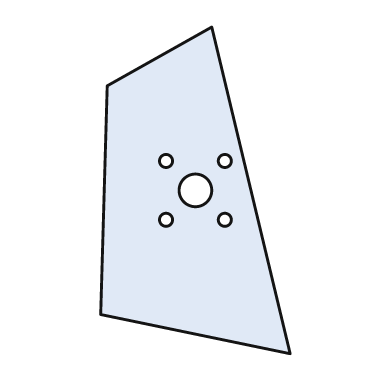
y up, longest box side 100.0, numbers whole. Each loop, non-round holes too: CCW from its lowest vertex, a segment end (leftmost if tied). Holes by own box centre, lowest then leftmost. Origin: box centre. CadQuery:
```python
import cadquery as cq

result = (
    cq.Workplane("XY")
    .moveTo(29.0, -50.0)
    .lineTo(5.0, 50.0)
    .lineTo(-27.0, 32.0)
    .lineTo(-29.0, -38.0)
    .close()
    .moveTo(-9.0, -9.0)
    .circle(2.0)
    .moveTo(9.0, -9.0)
    .circle(2.0)
    .moveTo(0.0, 0.0)
    .circle(5.0)
    .moveTo(-9.0, 9.0)
    .circle(2.0)
    .moveTo(9.0, 9.0)
    .circle(2.0)
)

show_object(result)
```